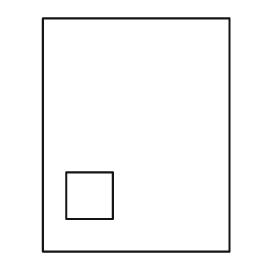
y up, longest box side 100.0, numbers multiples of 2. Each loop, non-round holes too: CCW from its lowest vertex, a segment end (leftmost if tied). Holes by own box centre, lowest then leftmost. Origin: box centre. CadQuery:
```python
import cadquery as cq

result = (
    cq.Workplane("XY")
    .moveTo(-40.0, -50.0)
    .lineTo(40.0, -50.0)
    .lineTo(40.0, 50.0)
    .lineTo(-40.0, 50.0)
    .close()
    .moveTo(-30.0, -36.0)
    .lineTo(-10.0, -36.0)
    .lineTo(-10.0, -16.0)
    .lineTo(-30.0, -16.0)
    .close()
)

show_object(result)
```